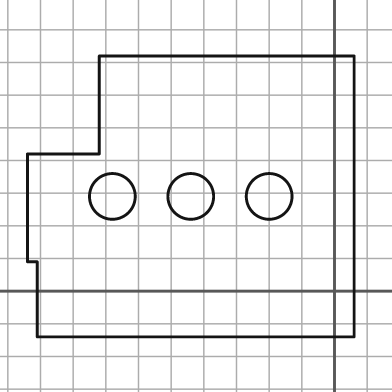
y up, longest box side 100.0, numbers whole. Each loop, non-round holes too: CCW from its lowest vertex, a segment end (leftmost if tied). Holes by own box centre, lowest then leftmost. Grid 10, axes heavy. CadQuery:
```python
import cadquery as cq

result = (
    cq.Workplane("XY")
    .moveTo(-91.0, -14.0)
    .lineTo(6.0, -14.0)
    .lineTo(6.0, 72.0)
    .lineTo(-72.0, 72.0)
    .lineTo(-72.0, 42.0)
    .lineTo(-94.0, 42.0)
    .lineTo(-94.0, 9.0)
    .lineTo(-91.0, 9.0)
    .close()
    .moveTo(-68.0, 29.0)
    .circle(7.0)
    .moveTo(-44.0, 29.0)
    .circle(7.0)
    .moveTo(-20.0, 29.0)
    .circle(7.0)
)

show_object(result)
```